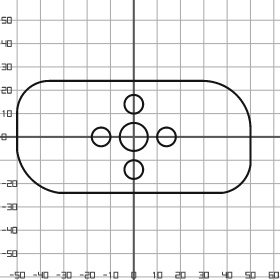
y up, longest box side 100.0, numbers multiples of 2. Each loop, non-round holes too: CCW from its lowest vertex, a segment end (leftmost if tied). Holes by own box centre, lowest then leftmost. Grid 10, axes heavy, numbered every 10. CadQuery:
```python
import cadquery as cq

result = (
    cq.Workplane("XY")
    .moveTo(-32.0, -24.0)
    .lineTo(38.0, -24.0)
    .threePointArc((46.0, -20.0), (50.0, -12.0))
    .lineTo(50.0, 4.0)
    .threePointArc((44.0, 18.0), (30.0, 24.0))
    .lineTo(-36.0, 24.0)
    .threePointArc((-46.0, 20.0), (-50.0, 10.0))
    .lineTo(-50.0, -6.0)
    .threePointArc((-44.0, -18.0), (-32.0, -24.0))
    .close()
    .moveTo(0.0, -14.0)
    .circle(4.0)
    .moveTo(-14.0, 0.0)
    .circle(4.0)
    .moveTo(0.0, 0.0)
    .circle(6.0)
    .moveTo(14.0, 0.0)
    .circle(4.0)
    .moveTo(0.0, 14.0)
    .circle(4.0)
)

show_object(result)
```